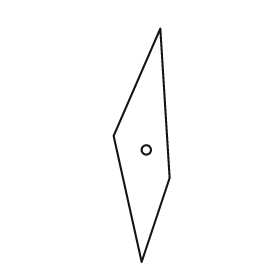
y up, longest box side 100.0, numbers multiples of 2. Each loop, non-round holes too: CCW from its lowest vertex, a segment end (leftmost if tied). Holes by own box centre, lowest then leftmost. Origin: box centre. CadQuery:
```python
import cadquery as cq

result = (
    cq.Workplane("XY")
    .moveTo(0.0, -50.0)
    .lineTo(12.0, -14.0)
    .lineTo(8.0, 50.0)
    .lineTo(-12.0, 4.0)
    .close()
    .moveTo(2.0, -2.0)
    .circle(2.0)
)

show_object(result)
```